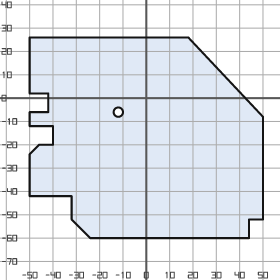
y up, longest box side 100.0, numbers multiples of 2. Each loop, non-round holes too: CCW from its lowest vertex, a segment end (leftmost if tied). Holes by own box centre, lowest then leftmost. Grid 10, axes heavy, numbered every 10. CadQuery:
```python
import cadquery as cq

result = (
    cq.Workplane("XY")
    .moveTo(-24.0, -60.0)
    .lineTo(44.0, -60.0)
    .lineTo(44.0, -52.0)
    .lineTo(50.0, -52.0)
    .lineTo(50.0, -8.0)
    .lineTo(18.0, 26.0)
    .lineTo(-50.0, 26.0)
    .lineTo(-50.0, 2.0)
    .lineTo(-42.0, 2.0)
    .lineTo(-42.0, -6.0)
    .lineTo(-50.0, -6.0)
    .lineTo(-50.0, -12.0)
    .lineTo(-40.0, -12.0)
    .lineTo(-40.0, -20.0)
    .lineTo(-46.0, -20.0)
    .lineTo(-50.0, -24.0)
    .lineTo(-50.0, -42.0)
    .lineTo(-32.0, -42.0)
    .lineTo(-32.0, -52.0)
    .close()
    .moveTo(-12.0, -6.0)
    .circle(2.0)
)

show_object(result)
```